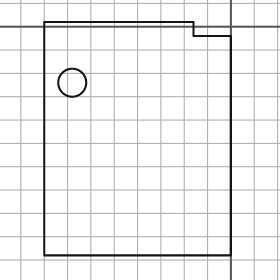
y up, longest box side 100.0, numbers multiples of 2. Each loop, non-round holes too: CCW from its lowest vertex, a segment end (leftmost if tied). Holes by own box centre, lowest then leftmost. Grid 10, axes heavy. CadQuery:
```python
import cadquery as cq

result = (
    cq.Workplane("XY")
    .moveTo(-80.0, -98.0)
    .lineTo(0.0, -98.0)
    .lineTo(0.0, -4.0)
    .lineTo(-16.0, -4.0)
    .lineTo(-16.0, 2.0)
    .lineTo(-80.0, 2.0)
    .close()
    .moveTo(-68.0, -24.0)
    .circle(6.0)
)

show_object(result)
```